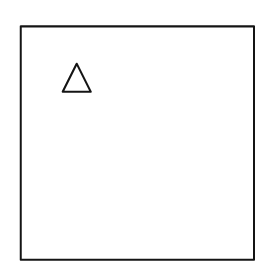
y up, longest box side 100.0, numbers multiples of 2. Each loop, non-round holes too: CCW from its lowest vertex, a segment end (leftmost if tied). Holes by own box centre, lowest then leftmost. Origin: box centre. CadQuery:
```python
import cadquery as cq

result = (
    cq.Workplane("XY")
    .moveTo(-50.0, -50.0)
    .lineTo(50.0, -50.0)
    .lineTo(50.0, 50.0)
    .lineTo(-50.0, 50.0)
    .close()
    .moveTo(-32.0, 22.0)
    .lineTo(-20.0, 22.0)
    .lineTo(-26.0, 34.0)
    .close()
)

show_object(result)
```